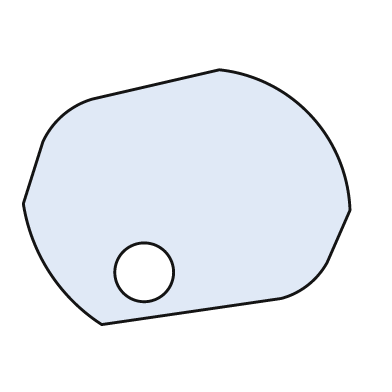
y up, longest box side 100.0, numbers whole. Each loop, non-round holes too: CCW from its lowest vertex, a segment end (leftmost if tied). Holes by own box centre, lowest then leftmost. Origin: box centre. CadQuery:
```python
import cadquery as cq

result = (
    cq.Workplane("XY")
    .moveTo(-26.0, -39.0)
    .lineTo(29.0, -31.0)
    .threePointArc((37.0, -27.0), (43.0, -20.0))
    .lineTo(50.0, -4.0)
    .threePointArc((38.0, 25.0), (10.0, 39.0))
    .lineTo(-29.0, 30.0)
    .threePointArc((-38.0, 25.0), (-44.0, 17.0))
    .lineTo(-50.0, -2.0)
    .threePointArc((-42.0, -23.0), (-26.0, -39.0))
    .close()
    .moveTo(-13.0, -23.0)
    .circle(9.0)
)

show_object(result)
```